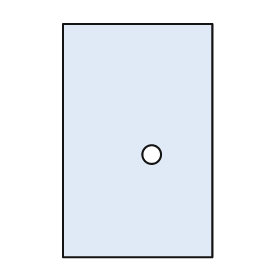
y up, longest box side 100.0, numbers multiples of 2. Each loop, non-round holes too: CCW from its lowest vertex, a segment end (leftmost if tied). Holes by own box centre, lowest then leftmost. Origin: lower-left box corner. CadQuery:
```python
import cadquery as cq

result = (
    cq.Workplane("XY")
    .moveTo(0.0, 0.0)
    .lineTo(64.0, 0.0)
    .lineTo(64.0, 100.0)
    .lineTo(0.0, 100.0)
    .close()
    .moveTo(38.0, 44.0)
    .circle(4.0)
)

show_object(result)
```